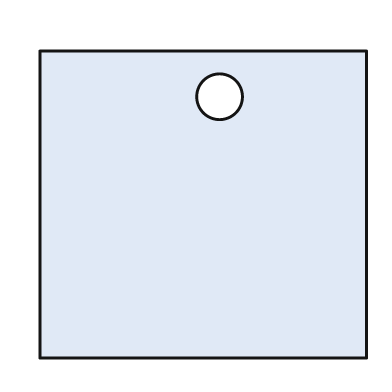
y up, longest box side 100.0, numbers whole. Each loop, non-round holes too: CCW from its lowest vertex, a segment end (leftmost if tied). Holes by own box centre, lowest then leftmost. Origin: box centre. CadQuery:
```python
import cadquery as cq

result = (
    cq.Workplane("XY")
    .moveTo(-50.0, -47.0)
    .lineTo(50.0, -47.0)
    .lineTo(50.0, 47.0)
    .lineTo(-50.0, 47.0)
    .close()
    .moveTo(5.0, 33.0)
    .circle(7.0)
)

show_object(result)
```